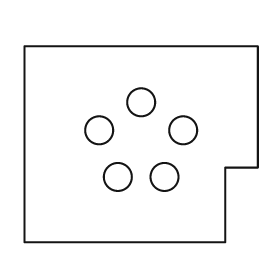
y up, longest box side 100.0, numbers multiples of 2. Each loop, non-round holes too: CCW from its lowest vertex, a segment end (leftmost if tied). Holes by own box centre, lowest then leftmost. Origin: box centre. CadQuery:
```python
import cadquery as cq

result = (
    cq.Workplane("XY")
    .moveTo(-50.0, -42.0)
    .lineTo(36.0, -42.0)
    .lineTo(36.0, -10.0)
    .lineTo(50.0, -10.0)
    .lineTo(50.0, 42.0)
    .lineTo(-50.0, 42.0)
    .close()
    .moveTo(-10.0, -14.0)
    .circle(6.0)
    .moveTo(10.0, -14.0)
    .circle(6.0)
    .moveTo(-18.0, 6.0)
    .circle(6.0)
    .moveTo(18.0, 6.0)
    .circle(6.0)
    .moveTo(0.0, 18.0)
    .circle(6.0)
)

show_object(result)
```